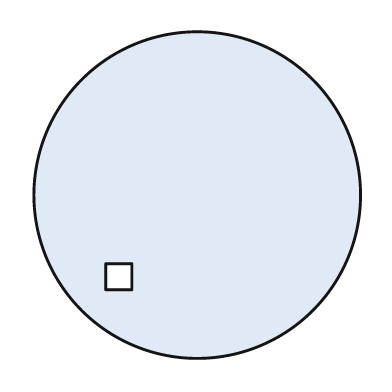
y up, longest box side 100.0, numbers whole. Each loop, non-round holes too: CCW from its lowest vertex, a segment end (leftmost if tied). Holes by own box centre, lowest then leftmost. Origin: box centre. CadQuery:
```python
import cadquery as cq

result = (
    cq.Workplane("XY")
    .moveTo(0.0, 0.0)
    .circle(50.0)
    .moveTo(-28.0, -29.0)
    .lineTo(-20.0, -29.0)
    .lineTo(-20.0, -21.0)
    .lineTo(-28.0, -21.0)
    .close()
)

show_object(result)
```